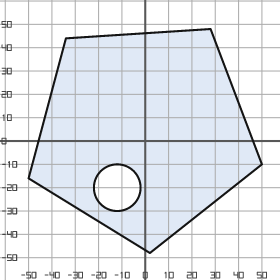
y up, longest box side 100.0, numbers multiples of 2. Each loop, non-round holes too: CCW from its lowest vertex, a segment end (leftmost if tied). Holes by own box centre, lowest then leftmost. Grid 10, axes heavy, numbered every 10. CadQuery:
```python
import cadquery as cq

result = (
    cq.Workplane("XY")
    .moveTo(2.0, -48.0)
    .lineTo(50.0, -10.0)
    .lineTo(28.0, 48.0)
    .lineTo(-34.0, 44.0)
    .lineTo(-50.0, -16.0)
    .close()
    .moveTo(-12.0, -20.0)
    .circle(10.0)
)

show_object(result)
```